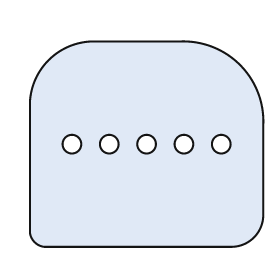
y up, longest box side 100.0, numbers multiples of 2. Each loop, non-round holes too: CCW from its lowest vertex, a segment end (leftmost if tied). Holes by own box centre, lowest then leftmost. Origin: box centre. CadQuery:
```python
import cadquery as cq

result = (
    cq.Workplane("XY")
    .moveTo(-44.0, -44.0)
    .lineTo(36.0, -44.0)
    .threePointArc((46.0, -40.0), (50.0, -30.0))
    .lineTo(50.0, 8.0)
    .threePointArc((40.0, 34.0), (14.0, 44.0))
    .lineTo(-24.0, 44.0)
    .threePointArc((-42.0, 36.0), (-50.0, 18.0))
    .lineTo(-50.0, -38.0)
    .threePointArc((-48.0, -42.0), (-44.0, -44.0))
    .close()
    .moveTo(-32.0, 0.0)
    .circle(4.0)
    .moveTo(-16.0, 0.0)
    .circle(4.0)
    .moveTo(0.0, 0.0)
    .circle(4.0)
    .moveTo(16.0, 0.0)
    .circle(4.0)
    .moveTo(32.0, 0.0)
    .circle(4.0)
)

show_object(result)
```